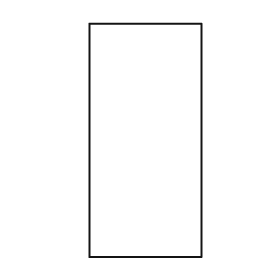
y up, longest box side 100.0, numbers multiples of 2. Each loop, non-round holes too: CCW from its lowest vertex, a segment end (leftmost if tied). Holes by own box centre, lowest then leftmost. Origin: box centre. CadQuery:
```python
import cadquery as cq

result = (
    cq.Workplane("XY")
    .moveTo(-24.0, -50.0)
    .lineTo(24.0, -50.0)
    .lineTo(24.0, 50.0)
    .lineTo(-24.0, 50.0)
    .close()
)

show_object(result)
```